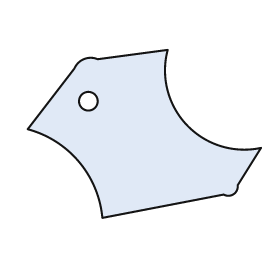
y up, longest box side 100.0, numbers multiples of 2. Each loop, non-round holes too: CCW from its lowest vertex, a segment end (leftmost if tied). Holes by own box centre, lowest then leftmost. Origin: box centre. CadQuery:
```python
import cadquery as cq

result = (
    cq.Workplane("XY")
    .moveTo(-18.0, -36.0)
    .lineTo(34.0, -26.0)
    .threePointArc((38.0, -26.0), (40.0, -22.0))
    .lineTo(50.0, -6.0)
    .threePointArc((18.0, 4.0), (10.0, 36.0))
    .lineTo(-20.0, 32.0)
    .threePointArc((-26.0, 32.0), (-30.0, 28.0))
    .lineTo(-50.0, 2.0)
    .threePointArc((-28.0, -12.0), (-18.0, -36.0))
    .close()
    .moveTo(-24.0, 14.0)
    .circle(4.0)
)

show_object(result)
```